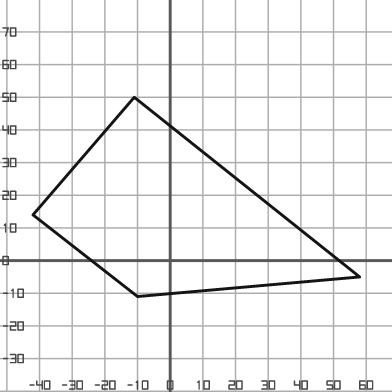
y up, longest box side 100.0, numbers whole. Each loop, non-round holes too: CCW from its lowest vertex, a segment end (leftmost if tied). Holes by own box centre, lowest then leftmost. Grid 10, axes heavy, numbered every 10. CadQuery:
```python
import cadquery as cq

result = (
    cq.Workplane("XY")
    .moveTo(-10.0, -11.0)
    .lineTo(58.0, -5.0)
    .lineTo(-11.0, 50.0)
    .lineTo(-42.0, 14.0)
    .close()
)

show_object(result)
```